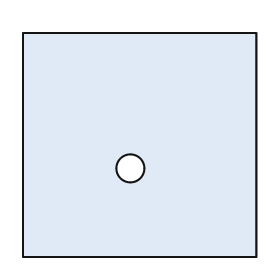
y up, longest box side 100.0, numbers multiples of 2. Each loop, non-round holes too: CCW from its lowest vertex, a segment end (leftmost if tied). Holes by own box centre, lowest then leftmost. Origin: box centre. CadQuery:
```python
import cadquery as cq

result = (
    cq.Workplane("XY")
    .moveTo(-50.0, -48.0)
    .lineTo(50.0, -48.0)
    .lineTo(50.0, 48.0)
    .lineTo(-50.0, 48.0)
    .close()
    .moveTo(-4.0, -10.0)
    .circle(6.0)
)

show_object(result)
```